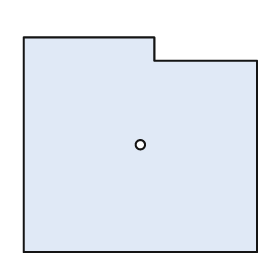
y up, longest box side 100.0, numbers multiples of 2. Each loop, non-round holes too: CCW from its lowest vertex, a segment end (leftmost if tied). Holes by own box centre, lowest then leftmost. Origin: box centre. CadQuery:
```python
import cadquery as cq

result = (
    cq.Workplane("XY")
    .moveTo(-50.0, -46.0)
    .lineTo(50.0, -46.0)
    .lineTo(50.0, 36.0)
    .lineTo(6.0, 36.0)
    .lineTo(6.0, 46.0)
    .lineTo(-50.0, 46.0)
    .close()
    .moveTo(0.0, 0.0)
    .circle(2.0)
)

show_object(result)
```